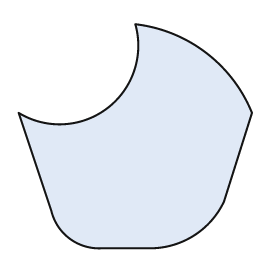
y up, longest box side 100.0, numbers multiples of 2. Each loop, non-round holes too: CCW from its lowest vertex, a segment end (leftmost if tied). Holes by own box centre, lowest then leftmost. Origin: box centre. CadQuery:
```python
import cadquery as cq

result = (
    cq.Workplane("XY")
    .moveTo(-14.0, -48.0)
    .lineTo(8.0, -48.0)
    .threePointArc((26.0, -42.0), (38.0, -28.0))
    .lineTo(50.0, 10.0)
    .threePointArc((30.0, 36.0), (0.0, 48.0))
    .threePointArc((-12.0, 12.0), (-50.0, 10.0))
    .lineTo(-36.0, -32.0)
    .threePointArc((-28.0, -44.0), (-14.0, -48.0))
    .close()
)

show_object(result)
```